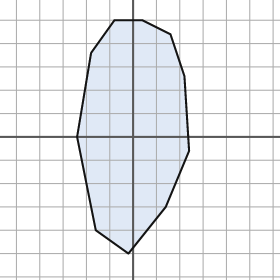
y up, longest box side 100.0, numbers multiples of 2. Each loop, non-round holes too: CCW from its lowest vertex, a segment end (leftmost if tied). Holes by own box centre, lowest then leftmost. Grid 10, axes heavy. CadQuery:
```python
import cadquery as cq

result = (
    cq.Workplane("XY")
    .moveTo(-2.0, -50.0)
    .lineTo(14.0, -30.0)
    .lineTo(24.0, -6.0)
    .lineTo(22.0, 26.0)
    .lineTo(16.0, 44.0)
    .lineTo(4.0, 50.0)
    .lineTo(-8.0, 50.0)
    .lineTo(-18.0, 36.0)
    .lineTo(-24.0, 0.0)
    .lineTo(-16.0, -40.0)
    .close()
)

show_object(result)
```